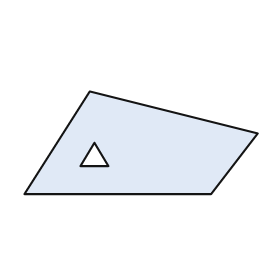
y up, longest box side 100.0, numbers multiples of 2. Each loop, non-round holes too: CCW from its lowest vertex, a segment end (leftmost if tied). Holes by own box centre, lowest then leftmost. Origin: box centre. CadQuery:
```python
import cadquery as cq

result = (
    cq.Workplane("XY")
    .moveTo(-50.0, -22.0)
    .lineTo(30.0, -22.0)
    .lineTo(50.0, 4.0)
    .lineTo(-22.0, 22.0)
    .close()
    .moveTo(-26.0, -10.0)
    .lineTo(-14.0, -10.0)
    .lineTo(-20.0, 0.0)
    .close()
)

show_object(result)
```